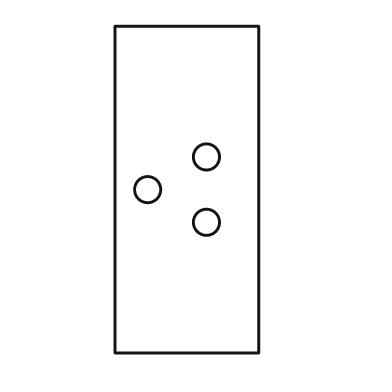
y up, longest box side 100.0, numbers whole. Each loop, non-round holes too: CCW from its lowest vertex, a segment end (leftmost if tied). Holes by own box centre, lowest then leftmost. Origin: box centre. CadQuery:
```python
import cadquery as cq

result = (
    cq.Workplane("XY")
    .moveTo(-22.0, -50.0)
    .lineTo(22.0, -50.0)
    .lineTo(22.0, 50.0)
    .lineTo(-22.0, 50.0)
    .close()
    .moveTo(6.0, -10.0)
    .circle(4.0)
    .moveTo(-12.0, 0.0)
    .circle(4.0)
    .moveTo(6.0, 10.0)
    .circle(4.0)
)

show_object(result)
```